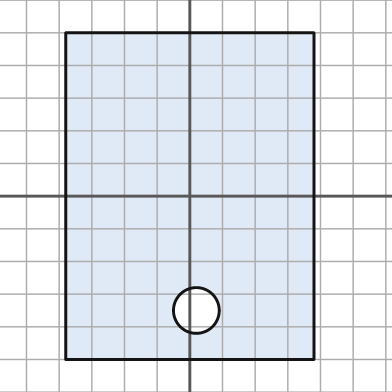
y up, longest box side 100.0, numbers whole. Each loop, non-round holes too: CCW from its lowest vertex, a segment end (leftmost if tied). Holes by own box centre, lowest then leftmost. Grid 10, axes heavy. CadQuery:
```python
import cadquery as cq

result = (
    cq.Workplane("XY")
    .moveTo(-38.0, -50.0)
    .lineTo(38.0, -50.0)
    .lineTo(38.0, 50.0)
    .lineTo(-38.0, 50.0)
    .close()
    .moveTo(2.0, -35.0)
    .circle(7.0)
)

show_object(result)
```